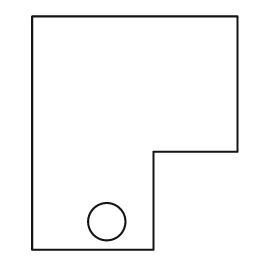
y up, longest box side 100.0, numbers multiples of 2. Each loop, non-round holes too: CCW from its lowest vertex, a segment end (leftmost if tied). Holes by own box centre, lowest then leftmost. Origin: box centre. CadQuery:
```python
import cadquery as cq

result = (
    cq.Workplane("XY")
    .moveTo(-44.0, -50.0)
    .lineTo(8.0, -50.0)
    .lineTo(8.0, -8.0)
    .lineTo(44.0, -8.0)
    .lineTo(44.0, 50.0)
    .lineTo(-44.0, 50.0)
    .close()
    .moveTo(-12.0, -38.0)
    .circle(8.0)
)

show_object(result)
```